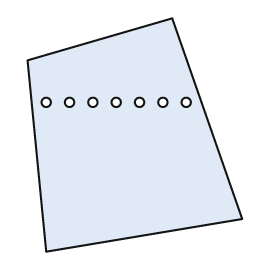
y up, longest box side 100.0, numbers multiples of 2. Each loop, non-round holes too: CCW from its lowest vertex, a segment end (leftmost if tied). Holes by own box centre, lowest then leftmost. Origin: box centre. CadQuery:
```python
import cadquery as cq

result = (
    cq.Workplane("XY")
    .moveTo(-38.0, -50.0)
    .lineTo(46.0, -36.0)
    .lineTo(16.0, 50.0)
    .lineTo(-46.0, 32.0)
    .close()
    .moveTo(-38.0, 14.0)
    .circle(2.0)
    .moveTo(-28.0, 14.0)
    .circle(2.0)
    .moveTo(-18.0, 14.0)
    .circle(2.0)
    .moveTo(-8.0, 14.0)
    .circle(2.0)
    .moveTo(2.0, 14.0)
    .circle(2.0)
    .moveTo(12.0, 14.0)
    .circle(2.0)
    .moveTo(22.0, 14.0)
    .circle(2.0)
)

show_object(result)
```